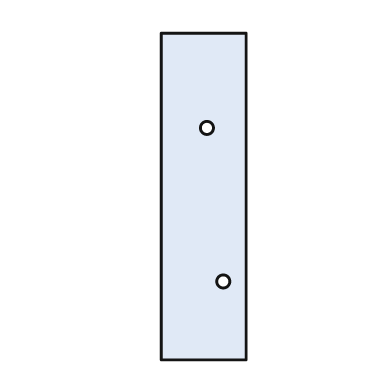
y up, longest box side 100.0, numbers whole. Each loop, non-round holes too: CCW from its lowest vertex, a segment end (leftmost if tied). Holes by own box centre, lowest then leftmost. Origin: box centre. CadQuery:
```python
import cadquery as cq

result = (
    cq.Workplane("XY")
    .moveTo(-13.0, -50.0)
    .lineTo(13.0, -50.0)
    .lineTo(13.0, 50.0)
    .lineTo(-13.0, 50.0)
    .close()
    .moveTo(6.0, -26.0)
    .circle(2.0)
    .moveTo(1.0, 21.0)
    .circle(2.0)
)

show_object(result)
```